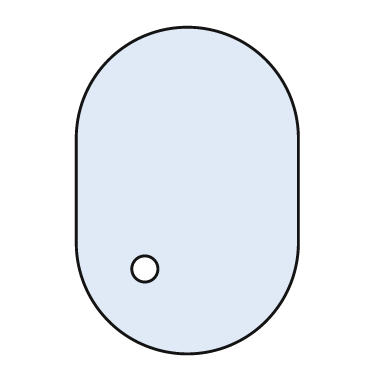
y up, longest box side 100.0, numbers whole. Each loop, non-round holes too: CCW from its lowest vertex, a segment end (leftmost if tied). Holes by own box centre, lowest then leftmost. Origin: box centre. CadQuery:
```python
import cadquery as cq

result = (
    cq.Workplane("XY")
    .moveTo(-34.0, -16.0)
    .threePointArc((0.0, -50.0), (34.0, -16.0))
    .lineTo(34.0, 16.0)
    .threePointArc((0.0, 50.0), (-34.0, 16.0))
    .close()
    .moveTo(-13.0, -24.0)
    .circle(4.0)
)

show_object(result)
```